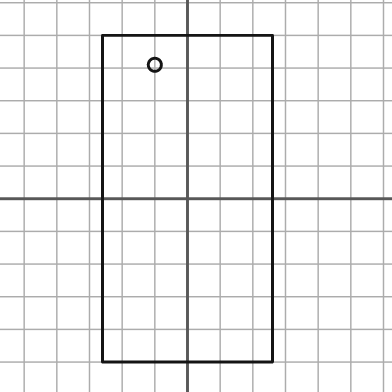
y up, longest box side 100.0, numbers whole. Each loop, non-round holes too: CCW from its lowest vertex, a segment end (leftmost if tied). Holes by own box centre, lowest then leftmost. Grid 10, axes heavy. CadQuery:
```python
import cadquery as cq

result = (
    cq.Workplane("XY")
    .moveTo(-26.0, -50.0)
    .lineTo(26.0, -50.0)
    .lineTo(26.0, 50.0)
    .lineTo(-26.0, 50.0)
    .close()
    .moveTo(-10.0, 41.0)
    .circle(2.0)
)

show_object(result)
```